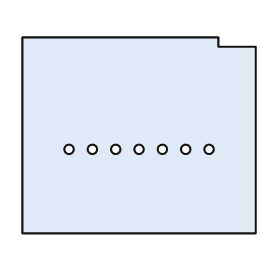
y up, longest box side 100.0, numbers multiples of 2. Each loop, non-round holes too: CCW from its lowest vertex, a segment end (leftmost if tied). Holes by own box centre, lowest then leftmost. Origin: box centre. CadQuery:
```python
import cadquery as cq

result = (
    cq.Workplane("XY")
    .moveTo(-50.0, -42.0)
    .lineTo(50.0, -42.0)
    .lineTo(50.0, 38.0)
    .lineTo(34.0, 38.0)
    .lineTo(34.0, 42.0)
    .lineTo(-50.0, 42.0)
    .close()
    .moveTo(-30.0, -6.0)
    .circle(2.0)
    .moveTo(-20.0, -6.0)
    .circle(2.0)
    .moveTo(-10.0, -6.0)
    .circle(2.0)
    .moveTo(0.0, -6.0)
    .circle(2.0)
    .moveTo(10.0, -6.0)
    .circle(2.0)
    .moveTo(20.0, -6.0)
    .circle(2.0)
    .moveTo(30.0, -6.0)
    .circle(2.0)
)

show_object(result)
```